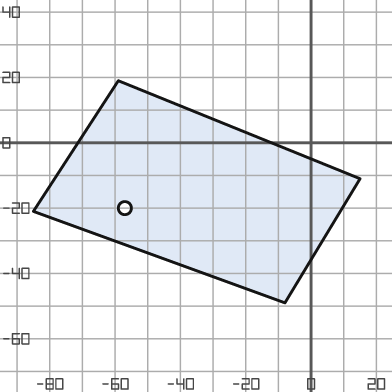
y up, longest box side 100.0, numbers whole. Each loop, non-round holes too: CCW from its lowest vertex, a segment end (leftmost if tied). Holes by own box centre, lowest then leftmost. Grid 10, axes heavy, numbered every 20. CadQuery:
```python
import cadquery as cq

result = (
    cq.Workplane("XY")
    .moveTo(-8.0, -49.0)
    .lineTo(15.0, -11.0)
    .lineTo(-59.0, 19.0)
    .lineTo(-85.0, -21.0)
    .close()
    .moveTo(-57.0, -20.0)
    .circle(2.0)
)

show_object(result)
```